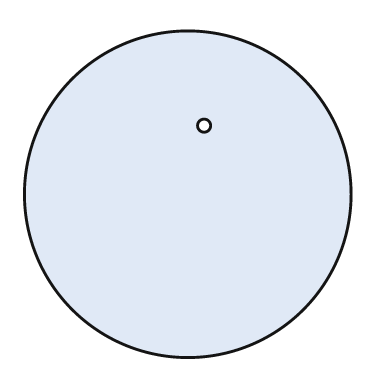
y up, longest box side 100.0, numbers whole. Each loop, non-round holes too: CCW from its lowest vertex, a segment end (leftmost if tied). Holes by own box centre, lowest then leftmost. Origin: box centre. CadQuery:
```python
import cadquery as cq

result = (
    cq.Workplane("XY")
    .moveTo(0.0, 0.0)
    .circle(50.0)
    .moveTo(5.0, 21.0)
    .circle(2.0)
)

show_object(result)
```